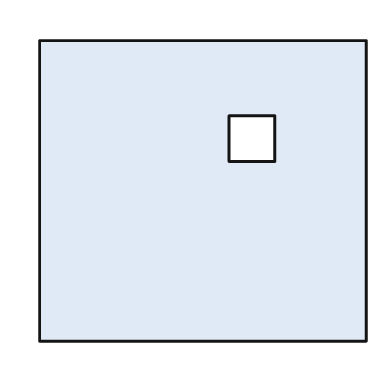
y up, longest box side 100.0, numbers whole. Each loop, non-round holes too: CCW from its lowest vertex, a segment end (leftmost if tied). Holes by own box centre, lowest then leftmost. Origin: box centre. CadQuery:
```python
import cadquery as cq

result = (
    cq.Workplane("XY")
    .moveTo(-50.0, -46.0)
    .lineTo(50.0, -46.0)
    .lineTo(50.0, 46.0)
    .lineTo(-50.0, 46.0)
    .close()
    .moveTo(8.0, 9.0)
    .lineTo(22.0, 9.0)
    .lineTo(22.0, 23.0)
    .lineTo(8.0, 23.0)
    .close()
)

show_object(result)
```